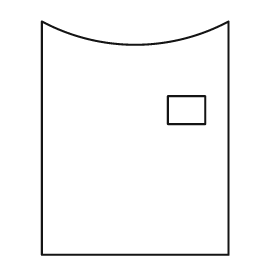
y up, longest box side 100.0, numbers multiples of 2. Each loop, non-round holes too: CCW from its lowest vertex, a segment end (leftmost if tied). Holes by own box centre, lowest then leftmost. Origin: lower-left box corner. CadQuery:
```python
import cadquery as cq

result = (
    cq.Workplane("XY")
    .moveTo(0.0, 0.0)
    .lineTo(80.0, 0.0)
    .lineTo(80.0, 100.0)
    .threePointArc((40.0, 90.0), (0.0, 100.0))
    .close()
    .moveTo(54.0, 56.0)
    .lineTo(70.0, 56.0)
    .lineTo(70.0, 68.0)
    .lineTo(54.0, 68.0)
    .close()
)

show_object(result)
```